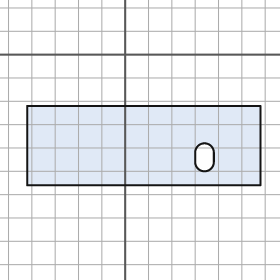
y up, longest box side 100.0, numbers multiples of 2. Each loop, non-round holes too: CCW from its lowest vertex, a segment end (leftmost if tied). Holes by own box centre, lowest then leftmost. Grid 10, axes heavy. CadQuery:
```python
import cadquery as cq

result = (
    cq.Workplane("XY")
    .moveTo(-42.0, -56.0)
    .lineTo(58.0, -56.0)
    .lineTo(58.0, -22.0)
    .lineTo(-42.0, -22.0)
    .close()
    .moveTo(30.0, -46.0)
    .threePointArc((34.0, -50.0), (38.0, -46.0))
    .lineTo(38.0, -42.0)
    .threePointArc((34.0, -38.0), (30.0, -42.0))
    .close()
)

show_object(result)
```